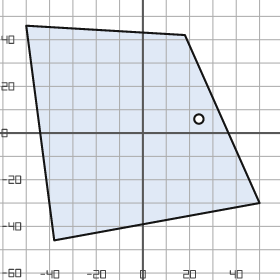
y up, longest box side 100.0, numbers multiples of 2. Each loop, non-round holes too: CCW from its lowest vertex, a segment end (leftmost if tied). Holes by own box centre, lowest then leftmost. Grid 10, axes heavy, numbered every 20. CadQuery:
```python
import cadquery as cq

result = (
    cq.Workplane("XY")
    .moveTo(-38.0, -46.0)
    .lineTo(50.0, -30.0)
    .lineTo(18.0, 42.0)
    .lineTo(-50.0, 46.0)
    .close()
    .moveTo(24.0, 6.0)
    .circle(2.0)
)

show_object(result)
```